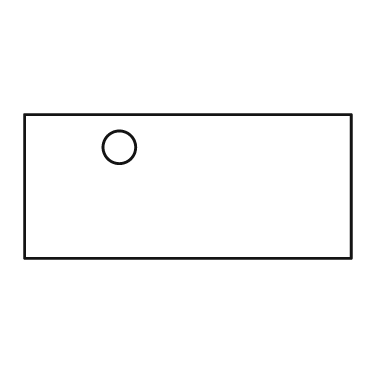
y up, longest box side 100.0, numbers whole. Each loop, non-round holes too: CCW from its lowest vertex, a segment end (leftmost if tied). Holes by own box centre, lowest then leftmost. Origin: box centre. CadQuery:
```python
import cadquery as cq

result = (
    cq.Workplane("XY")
    .moveTo(-50.0, -22.0)
    .lineTo(50.0, -22.0)
    .lineTo(50.0, 22.0)
    .lineTo(-50.0, 22.0)
    .close()
    .moveTo(-21.0, 12.0)
    .circle(5.0)
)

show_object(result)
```